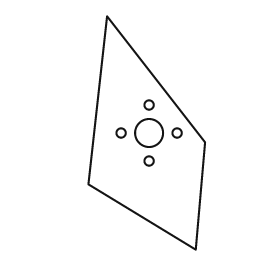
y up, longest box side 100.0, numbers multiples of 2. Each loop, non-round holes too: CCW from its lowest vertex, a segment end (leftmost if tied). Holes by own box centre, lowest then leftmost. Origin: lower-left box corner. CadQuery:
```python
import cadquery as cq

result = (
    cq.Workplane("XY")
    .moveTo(46.0, 0.0)
    .lineTo(50.0, 46.0)
    .lineTo(8.0, 100.0)
    .lineTo(0.0, 28.0)
    .close()
    .moveTo(26.0, 38.0)
    .circle(2.0)
    .moveTo(14.0, 50.0)
    .circle(2.0)
    .moveTo(26.0, 50.0)
    .circle(6.0)
    .moveTo(38.0, 50.0)
    .circle(2.0)
    .moveTo(26.0, 62.0)
    .circle(2.0)
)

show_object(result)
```